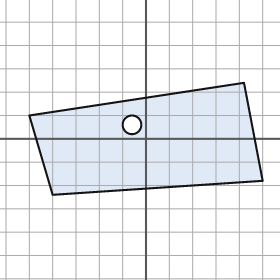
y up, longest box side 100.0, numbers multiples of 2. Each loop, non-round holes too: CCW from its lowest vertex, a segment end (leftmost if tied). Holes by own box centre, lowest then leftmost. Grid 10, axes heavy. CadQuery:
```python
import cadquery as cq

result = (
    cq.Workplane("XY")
    .moveTo(-40.0, -24.0)
    .lineTo(50.0, -18.0)
    .lineTo(42.0, 24.0)
    .lineTo(-50.0, 10.0)
    .close()
    .moveTo(-6.0, 6.0)
    .circle(4.0)
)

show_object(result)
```